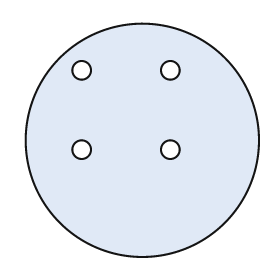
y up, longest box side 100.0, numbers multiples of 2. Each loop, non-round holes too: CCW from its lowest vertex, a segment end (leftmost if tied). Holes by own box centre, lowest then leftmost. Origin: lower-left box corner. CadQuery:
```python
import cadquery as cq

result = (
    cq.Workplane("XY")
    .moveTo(50.0, 50.0)
    .circle(50.0)
    .moveTo(24.0, 46.0)
    .circle(4.0)
    .moveTo(62.0, 46.0)
    .circle(4.0)
    .moveTo(24.0, 80.0)
    .circle(4.0)
    .moveTo(62.0, 80.0)
    .circle(4.0)
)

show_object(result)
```